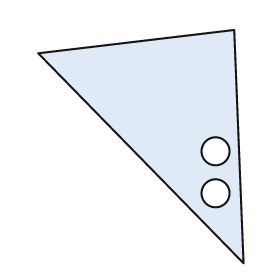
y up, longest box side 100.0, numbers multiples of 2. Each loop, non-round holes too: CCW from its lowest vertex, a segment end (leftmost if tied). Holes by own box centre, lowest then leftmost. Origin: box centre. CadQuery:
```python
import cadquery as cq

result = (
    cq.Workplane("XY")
    .moveTo(44.0, -50.0)
    .lineTo(40.0, 50.0)
    .lineTo(-44.0, 40.0)
    .close()
    .moveTo(32.0, -20.0)
    .circle(6.0)
    .moveTo(32.0, -2.0)
    .circle(6.0)
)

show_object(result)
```